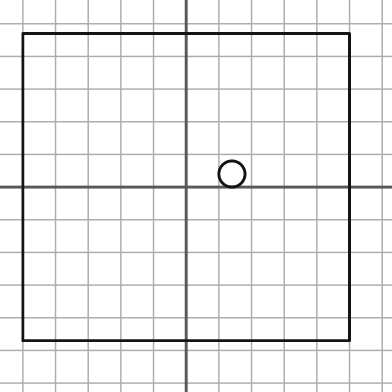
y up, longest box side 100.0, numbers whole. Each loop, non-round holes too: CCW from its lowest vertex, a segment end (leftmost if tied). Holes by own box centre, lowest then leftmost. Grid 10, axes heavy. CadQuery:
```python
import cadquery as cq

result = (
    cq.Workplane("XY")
    .moveTo(-50.0, -47.0)
    .lineTo(50.0, -47.0)
    .lineTo(50.0, 47.0)
    .lineTo(-50.0, 47.0)
    .close()
    .moveTo(14.0, 4.0)
    .circle(4.0)
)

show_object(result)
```